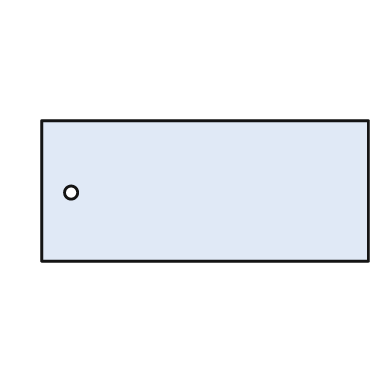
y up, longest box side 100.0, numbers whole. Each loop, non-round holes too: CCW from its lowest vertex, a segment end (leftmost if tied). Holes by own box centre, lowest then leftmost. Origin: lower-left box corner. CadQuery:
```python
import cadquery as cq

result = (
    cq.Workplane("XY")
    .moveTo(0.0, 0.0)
    .lineTo(100.0, 0.0)
    .lineTo(100.0, 43.0)
    .lineTo(0.0, 43.0)
    .close()
    .moveTo(9.0, 21.0)
    .circle(2.0)
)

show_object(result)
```